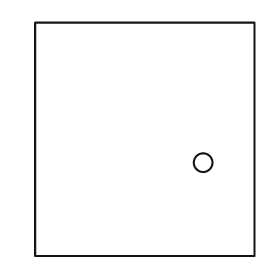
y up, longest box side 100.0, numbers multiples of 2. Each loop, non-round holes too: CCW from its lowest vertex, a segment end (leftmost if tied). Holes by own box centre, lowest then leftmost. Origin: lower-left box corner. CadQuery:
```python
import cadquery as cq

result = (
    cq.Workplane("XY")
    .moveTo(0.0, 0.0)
    .lineTo(94.0, 0.0)
    .lineTo(94.0, 100.0)
    .lineTo(0.0, 100.0)
    .close()
    .moveTo(72.0, 40.0)
    .circle(4.0)
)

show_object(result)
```